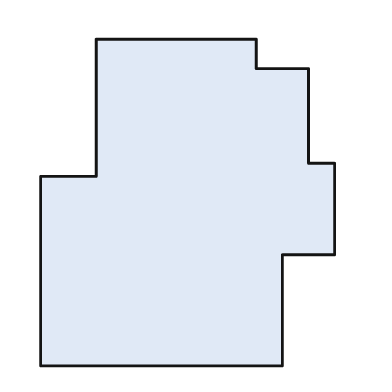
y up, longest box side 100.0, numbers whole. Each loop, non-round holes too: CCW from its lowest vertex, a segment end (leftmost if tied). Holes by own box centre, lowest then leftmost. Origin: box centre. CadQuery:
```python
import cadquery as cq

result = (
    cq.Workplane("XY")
    .moveTo(-45.0, -50.0)
    .lineTo(29.0, -50.0)
    .lineTo(29.0, -16.0)
    .lineTo(45.0, -16.0)
    .lineTo(45.0, 12.0)
    .lineTo(37.0, 12.0)
    .lineTo(37.0, 41.0)
    .lineTo(21.0, 41.0)
    .lineTo(21.0, 50.0)
    .lineTo(-28.0, 50.0)
    .lineTo(-28.0, 8.0)
    .lineTo(-45.0, 8.0)
    .close()
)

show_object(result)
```